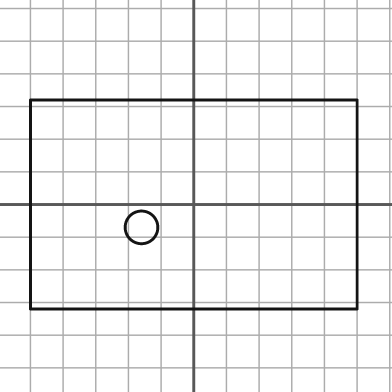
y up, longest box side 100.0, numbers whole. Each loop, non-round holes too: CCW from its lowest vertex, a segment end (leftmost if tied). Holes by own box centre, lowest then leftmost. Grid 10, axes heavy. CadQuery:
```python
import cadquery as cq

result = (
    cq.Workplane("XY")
    .moveTo(-50.0, -32.0)
    .lineTo(50.0, -32.0)
    .lineTo(50.0, 32.0)
    .lineTo(-50.0, 32.0)
    .close()
    .moveTo(-16.0, -7.0)
    .circle(5.0)
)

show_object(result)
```